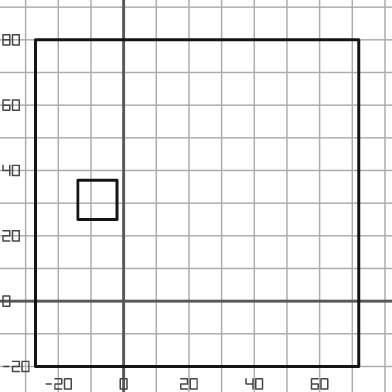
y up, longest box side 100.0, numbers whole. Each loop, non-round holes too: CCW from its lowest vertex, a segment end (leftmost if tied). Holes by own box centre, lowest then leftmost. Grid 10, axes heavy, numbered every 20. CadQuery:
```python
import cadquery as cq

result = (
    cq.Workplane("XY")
    .moveTo(-27.0, -20.0)
    .lineTo(72.0, -20.0)
    .lineTo(72.0, 80.0)
    .lineTo(-27.0, 80.0)
    .close()
    .moveTo(-14.0, 25.0)
    .lineTo(-2.0, 25.0)
    .lineTo(-2.0, 37.0)
    .lineTo(-14.0, 37.0)
    .close()
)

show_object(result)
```